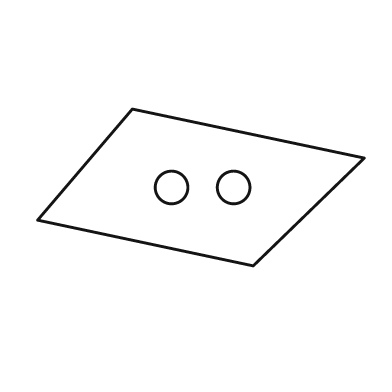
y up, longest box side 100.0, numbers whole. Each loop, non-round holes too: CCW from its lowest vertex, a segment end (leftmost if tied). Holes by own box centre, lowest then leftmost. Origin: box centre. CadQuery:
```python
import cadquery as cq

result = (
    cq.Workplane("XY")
    .moveTo(16.0, -24.0)
    .lineTo(50.0, 9.0)
    .lineTo(-21.0, 24.0)
    .lineTo(-50.0, -10.0)
    .close()
    .moveTo(-9.0, 0.0)
    .circle(5.0)
    .moveTo(10.0, 0.0)
    .circle(5.0)
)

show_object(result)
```